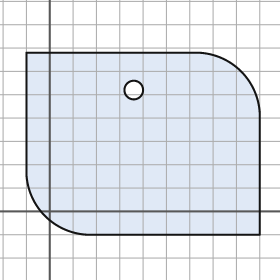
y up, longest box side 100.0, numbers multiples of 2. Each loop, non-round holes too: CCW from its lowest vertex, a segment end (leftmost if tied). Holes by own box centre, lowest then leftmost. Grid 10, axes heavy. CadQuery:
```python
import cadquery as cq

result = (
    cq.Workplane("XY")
    .moveTo(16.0, -10.0)
    .lineTo(90.0, -10.0)
    .lineTo(90.0, 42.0)
    .threePointArc((82.0, 60.0), (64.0, 68.0))
    .lineTo(-10.0, 68.0)
    .lineTo(-10.0, 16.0)
    .threePointArc((-2.0, -2.0), (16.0, -10.0))
    .close()
    .moveTo(36.0, 52.0)
    .circle(4.0)
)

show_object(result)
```